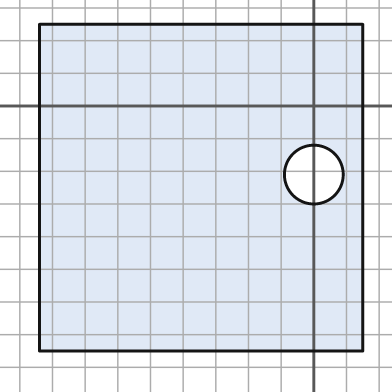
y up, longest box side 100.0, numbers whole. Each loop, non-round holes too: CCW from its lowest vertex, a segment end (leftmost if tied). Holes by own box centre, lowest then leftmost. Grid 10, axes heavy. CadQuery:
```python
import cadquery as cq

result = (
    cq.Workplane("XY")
    .moveTo(-84.0, -75.0)
    .lineTo(15.0, -75.0)
    .lineTo(15.0, 25.0)
    .lineTo(-84.0, 25.0)
    .close()
    .moveTo(0.0, -21.0)
    .circle(9.0)
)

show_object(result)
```